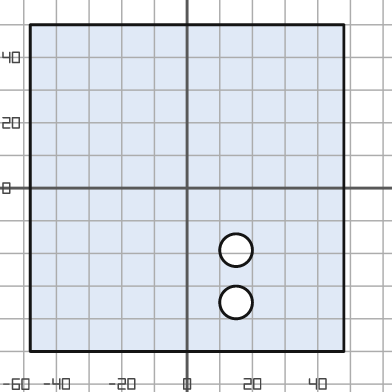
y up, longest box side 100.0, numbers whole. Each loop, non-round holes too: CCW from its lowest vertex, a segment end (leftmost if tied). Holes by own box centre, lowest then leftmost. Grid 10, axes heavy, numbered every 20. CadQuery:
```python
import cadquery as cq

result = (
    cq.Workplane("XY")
    .moveTo(-48.0, -50.0)
    .lineTo(48.0, -50.0)
    .lineTo(48.0, 50.0)
    .lineTo(-48.0, 50.0)
    .close()
    .moveTo(15.0, -35.0)
    .circle(5.0)
    .moveTo(15.0, -19.0)
    .circle(5.0)
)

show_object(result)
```